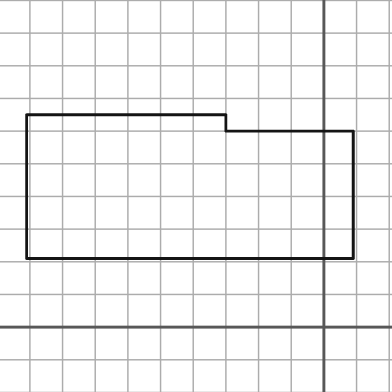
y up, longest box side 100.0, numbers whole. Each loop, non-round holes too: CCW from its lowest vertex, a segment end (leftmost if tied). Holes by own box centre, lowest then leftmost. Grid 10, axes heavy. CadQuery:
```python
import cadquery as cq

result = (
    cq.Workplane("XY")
    .moveTo(-91.0, 21.0)
    .lineTo(9.0, 21.0)
    .lineTo(9.0, 60.0)
    .lineTo(-30.0, 60.0)
    .lineTo(-30.0, 65.0)
    .lineTo(-91.0, 65.0)
    .close()
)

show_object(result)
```